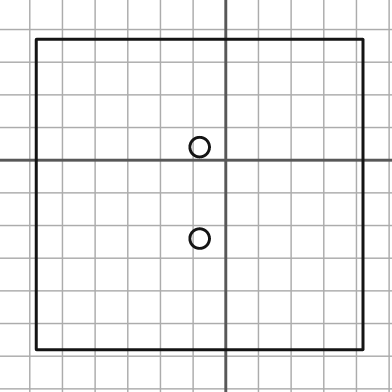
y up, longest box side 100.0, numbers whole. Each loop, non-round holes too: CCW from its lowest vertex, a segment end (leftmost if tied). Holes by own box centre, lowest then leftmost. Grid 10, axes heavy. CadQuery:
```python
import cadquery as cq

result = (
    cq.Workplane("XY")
    .moveTo(-58.0, -58.0)
    .lineTo(42.0, -58.0)
    .lineTo(42.0, 37.0)
    .lineTo(-58.0, 37.0)
    .close()
    .moveTo(-8.0, -24.0)
    .circle(3.0)
    .moveTo(-8.0, 4.0)
    .circle(3.0)
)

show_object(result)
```